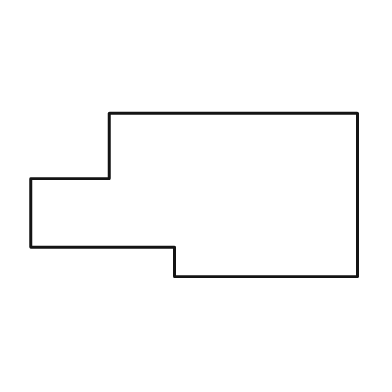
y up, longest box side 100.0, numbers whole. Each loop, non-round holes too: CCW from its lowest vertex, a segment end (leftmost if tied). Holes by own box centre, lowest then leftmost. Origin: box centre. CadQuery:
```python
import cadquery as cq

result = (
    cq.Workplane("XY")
    .moveTo(-6.0, -25.0)
    .lineTo(50.0, -25.0)
    .lineTo(50.0, 25.0)
    .lineTo(-26.0, 25.0)
    .lineTo(-26.0, 5.0)
    .lineTo(-50.0, 5.0)
    .lineTo(-50.0, -16.0)
    .lineTo(-6.0, -16.0)
    .close()
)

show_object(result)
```